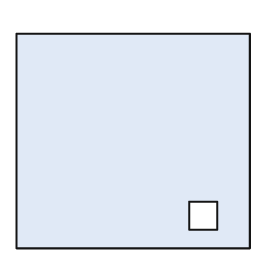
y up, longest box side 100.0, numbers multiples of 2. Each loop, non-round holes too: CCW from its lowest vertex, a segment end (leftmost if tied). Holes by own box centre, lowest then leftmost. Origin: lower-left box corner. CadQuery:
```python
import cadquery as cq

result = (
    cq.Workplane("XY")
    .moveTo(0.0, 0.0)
    .lineTo(100.0, 0.0)
    .lineTo(100.0, 92.0)
    .lineTo(0.0, 92.0)
    .close()
    .moveTo(74.0, 8.0)
    .lineTo(86.0, 8.0)
    .lineTo(86.0, 20.0)
    .lineTo(74.0, 20.0)
    .close()
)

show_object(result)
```